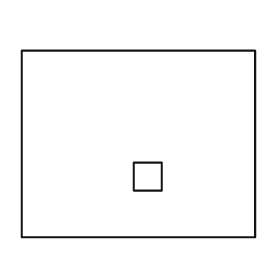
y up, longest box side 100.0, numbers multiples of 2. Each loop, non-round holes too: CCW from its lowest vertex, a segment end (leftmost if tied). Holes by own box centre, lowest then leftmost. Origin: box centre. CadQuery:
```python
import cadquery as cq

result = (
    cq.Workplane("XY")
    .moveTo(-50.0, -40.0)
    .lineTo(50.0, -40.0)
    .lineTo(50.0, 40.0)
    .lineTo(-50.0, 40.0)
    .close()
    .moveTo(-2.0, -20.0)
    .lineTo(10.0, -20.0)
    .lineTo(10.0, -8.0)
    .lineTo(-2.0, -8.0)
    .close()
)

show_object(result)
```